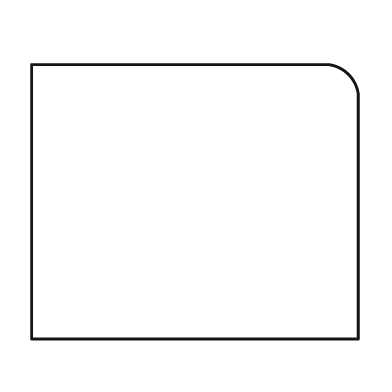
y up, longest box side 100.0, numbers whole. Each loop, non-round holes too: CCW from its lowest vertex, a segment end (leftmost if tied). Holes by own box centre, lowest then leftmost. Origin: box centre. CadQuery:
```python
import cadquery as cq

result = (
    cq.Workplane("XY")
    .moveTo(-50.0, -42.0)
    .lineTo(50.0, -42.0)
    .lineTo(50.0, 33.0)
    .threePointArc((47.0, 39.0), (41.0, 42.0))
    .lineTo(-50.0, 42.0)
    .close()
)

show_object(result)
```